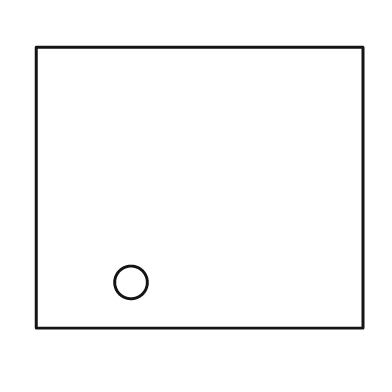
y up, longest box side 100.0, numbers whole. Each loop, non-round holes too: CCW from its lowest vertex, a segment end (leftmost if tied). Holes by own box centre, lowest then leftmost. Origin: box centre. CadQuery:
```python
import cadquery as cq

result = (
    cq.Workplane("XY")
    .moveTo(-50.0, -43.0)
    .lineTo(50.0, -43.0)
    .lineTo(50.0, 43.0)
    .lineTo(-50.0, 43.0)
    .close()
    .moveTo(-21.0, -29.0)
    .circle(5.0)
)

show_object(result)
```